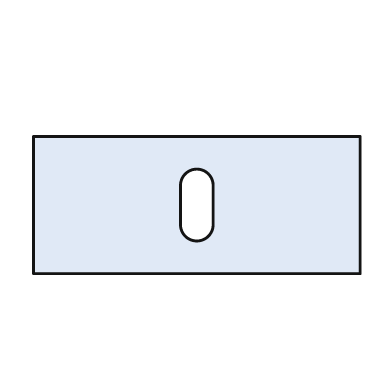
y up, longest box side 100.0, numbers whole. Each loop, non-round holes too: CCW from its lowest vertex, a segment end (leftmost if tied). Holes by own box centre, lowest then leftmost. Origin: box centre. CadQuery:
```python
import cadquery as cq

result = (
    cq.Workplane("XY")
    .moveTo(-50.0, -21.0)
    .lineTo(50.0, -21.0)
    .lineTo(50.0, 21.0)
    .lineTo(-50.0, 21.0)
    .close()
    .moveTo(-5.0, -6.0)
    .threePointArc((0.0, -11.0), (5.0, -6.0))
    .lineTo(5.0, 6.0)
    .threePointArc((0.0, 11.0), (-5.0, 6.0))
    .close()
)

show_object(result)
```